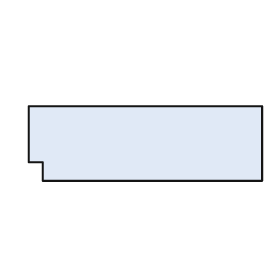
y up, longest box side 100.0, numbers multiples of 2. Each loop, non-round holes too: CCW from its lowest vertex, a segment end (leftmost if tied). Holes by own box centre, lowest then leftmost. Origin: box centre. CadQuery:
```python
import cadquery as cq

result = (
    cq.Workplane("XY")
    .moveTo(-44.0, -16.0)
    .lineTo(50.0, -16.0)
    .lineTo(50.0, 16.0)
    .lineTo(-50.0, 16.0)
    .lineTo(-50.0, -8.0)
    .lineTo(-44.0, -8.0)
    .close()
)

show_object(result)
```